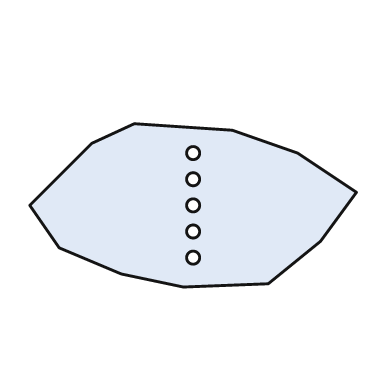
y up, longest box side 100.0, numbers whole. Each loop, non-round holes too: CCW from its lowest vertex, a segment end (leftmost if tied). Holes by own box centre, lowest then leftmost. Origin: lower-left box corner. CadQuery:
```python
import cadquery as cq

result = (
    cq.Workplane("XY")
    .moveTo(47.0, 0.0)
    .lineTo(73.0, 1.0)
    .lineTo(89.0, 14.0)
    .lineTo(100.0, 29.0)
    .lineTo(82.0, 41.0)
    .lineTo(62.0, 48.0)
    .lineTo(32.0, 50.0)
    .lineTo(19.0, 44.0)
    .lineTo(0.0, 25.0)
    .lineTo(9.0, 12.0)
    .lineTo(28.0, 4.0)
    .close()
    .moveTo(50.0, 9.0)
    .circle(2.0)
    .moveTo(50.0, 17.0)
    .circle(2.0)
    .moveTo(50.0, 25.0)
    .circle(2.0)
    .moveTo(50.0, 33.0)
    .circle(2.0)
    .moveTo(50.0, 41.0)
    .circle(2.0)
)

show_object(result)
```